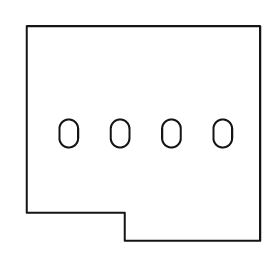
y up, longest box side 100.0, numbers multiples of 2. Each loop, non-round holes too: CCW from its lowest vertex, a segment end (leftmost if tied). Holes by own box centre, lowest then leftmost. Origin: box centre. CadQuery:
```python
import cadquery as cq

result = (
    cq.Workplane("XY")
    .moveTo(-8.0, -46.0)
    .lineTo(50.0, -46.0)
    .lineTo(50.0, 46.0)
    .lineTo(-50.0, 46.0)
    .lineTo(-50.0, -34.0)
    .lineTo(-8.0, -34.0)
    .close()
    .moveTo(-36.0, -2.0)
    .threePointArc((-32.0, -6.0), (-28.0, -2.0))
    .lineTo(-28.0, 2.0)
    .threePointArc((-32.0, 6.0), (-36.0, 2.0))
    .close()
    .moveTo(-14.0, -2.0)
    .threePointArc((-10.0, -6.0), (-6.0, -2.0))
    .lineTo(-6.0, 2.0)
    .threePointArc((-10.0, 6.0), (-14.0, 2.0))
    .close()
    .moveTo(8.0, -2.0)
    .threePointArc((12.0, -6.0), (16.0, -2.0))
    .lineTo(16.0, 2.0)
    .threePointArc((12.0, 6.0), (8.0, 2.0))
    .close()
    .moveTo(30.0, -2.0)
    .threePointArc((34.0, -6.0), (38.0, -2.0))
    .lineTo(38.0, 2.0)
    .threePointArc((34.0, 6.0), (30.0, 2.0))
    .close()
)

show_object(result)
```